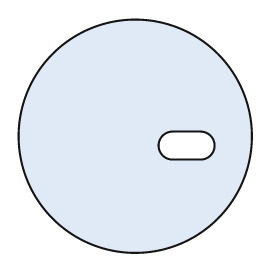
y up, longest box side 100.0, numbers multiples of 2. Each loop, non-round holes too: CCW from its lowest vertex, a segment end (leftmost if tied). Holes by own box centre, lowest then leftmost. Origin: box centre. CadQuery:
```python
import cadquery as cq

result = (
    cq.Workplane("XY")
    .moveTo(0.0, 0.0)
    .circle(50.0)
    .moveTo(16.0, -10.0)
    .lineTo(28.0, -10.0)
    .threePointArc((34.0, -4.0), (28.0, 2.0))
    .lineTo(16.0, 2.0)
    .threePointArc((10.0, -4.0), (16.0, -10.0))
    .close()
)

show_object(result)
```